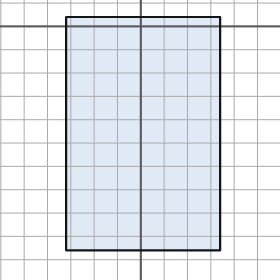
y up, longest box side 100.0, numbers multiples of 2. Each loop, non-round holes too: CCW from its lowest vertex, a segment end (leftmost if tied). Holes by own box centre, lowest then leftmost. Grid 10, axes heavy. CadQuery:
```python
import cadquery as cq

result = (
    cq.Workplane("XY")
    .moveTo(-32.0, -96.0)
    .lineTo(34.0, -96.0)
    .lineTo(34.0, 4.0)
    .lineTo(-32.0, 4.0)
    .close()
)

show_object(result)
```